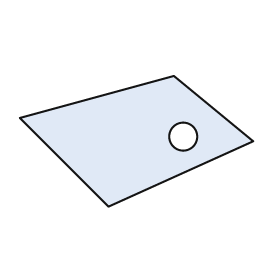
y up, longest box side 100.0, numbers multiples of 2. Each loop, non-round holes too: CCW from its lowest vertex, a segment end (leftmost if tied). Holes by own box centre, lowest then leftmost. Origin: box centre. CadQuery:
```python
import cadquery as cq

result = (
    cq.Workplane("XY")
    .moveTo(-12.0, -28.0)
    .lineTo(50.0, 0.0)
    .lineTo(16.0, 28.0)
    .lineTo(-50.0, 10.0)
    .close()
    .moveTo(20.0, 2.0)
    .circle(6.0)
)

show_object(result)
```